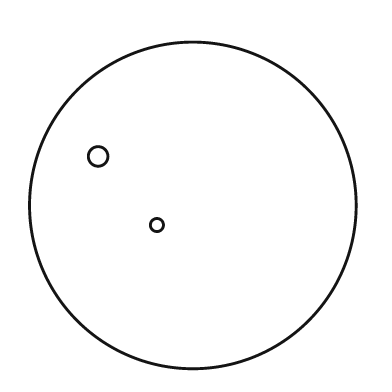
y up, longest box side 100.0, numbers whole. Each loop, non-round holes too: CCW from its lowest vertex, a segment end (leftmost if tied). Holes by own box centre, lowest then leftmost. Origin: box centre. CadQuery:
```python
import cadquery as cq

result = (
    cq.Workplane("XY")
    .moveTo(0.0, 0.0)
    .circle(50.0)
    .moveTo(-11.0, -6.0)
    .circle(2.0)
    .moveTo(-29.0, 15.0)
    .circle(3.0)
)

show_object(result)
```